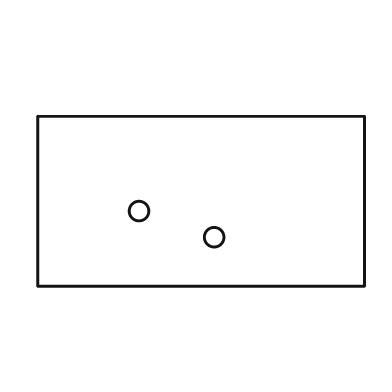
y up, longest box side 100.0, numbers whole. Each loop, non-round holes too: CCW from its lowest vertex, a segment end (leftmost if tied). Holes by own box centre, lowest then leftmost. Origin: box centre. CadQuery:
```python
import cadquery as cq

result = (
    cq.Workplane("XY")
    .moveTo(-50.0, -26.0)
    .lineTo(50.0, -26.0)
    .lineTo(50.0, 26.0)
    .lineTo(-50.0, 26.0)
    .close()
    .moveTo(4.0, -11.0)
    .circle(3.0)
    .moveTo(-19.0, -3.0)
    .circle(3.0)
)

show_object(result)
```